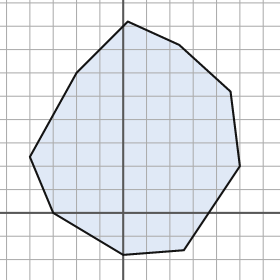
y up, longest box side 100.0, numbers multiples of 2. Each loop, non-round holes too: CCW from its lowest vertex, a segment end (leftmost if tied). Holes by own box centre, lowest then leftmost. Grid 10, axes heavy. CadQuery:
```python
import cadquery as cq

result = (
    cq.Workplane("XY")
    .moveTo(0.0, -18.0)
    .lineTo(26.0, -16.0)
    .lineTo(50.0, 20.0)
    .lineTo(46.0, 52.0)
    .lineTo(24.0, 72.0)
    .lineTo(2.0, 82.0)
    .lineTo(-20.0, 60.0)
    .lineTo(-40.0, 24.0)
    .lineTo(-30.0, 0.0)
    .close()
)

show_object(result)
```